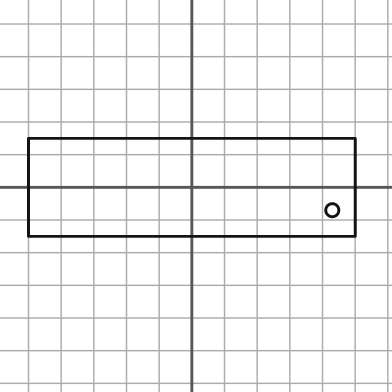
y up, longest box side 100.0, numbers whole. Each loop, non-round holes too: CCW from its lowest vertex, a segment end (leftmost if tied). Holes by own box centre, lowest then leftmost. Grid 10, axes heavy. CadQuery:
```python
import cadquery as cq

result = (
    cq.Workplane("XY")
    .moveTo(-50.0, -15.0)
    .lineTo(50.0, -15.0)
    .lineTo(50.0, 15.0)
    .lineTo(-50.0, 15.0)
    .close()
    .moveTo(43.0, -7.0)
    .circle(2.0)
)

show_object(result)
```